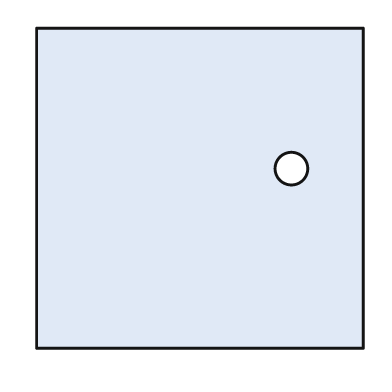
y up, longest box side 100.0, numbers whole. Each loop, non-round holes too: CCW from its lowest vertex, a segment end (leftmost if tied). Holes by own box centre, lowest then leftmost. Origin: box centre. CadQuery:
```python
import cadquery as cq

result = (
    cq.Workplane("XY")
    .moveTo(-50.0, -49.0)
    .lineTo(50.0, -49.0)
    .lineTo(50.0, 49.0)
    .lineTo(-50.0, 49.0)
    .close()
    .moveTo(28.0, 6.0)
    .circle(5.0)
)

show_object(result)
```